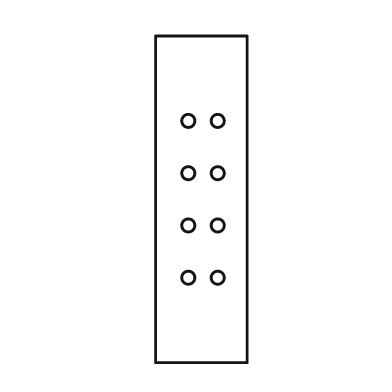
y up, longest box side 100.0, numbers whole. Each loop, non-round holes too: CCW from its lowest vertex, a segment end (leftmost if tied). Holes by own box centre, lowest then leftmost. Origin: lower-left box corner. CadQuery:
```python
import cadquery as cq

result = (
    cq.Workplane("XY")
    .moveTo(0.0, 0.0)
    .lineTo(28.0, 0.0)
    .lineTo(28.0, 100.0)
    .lineTo(0.0, 100.0)
    .close()
    .moveTo(10.0, 26.0)
    .circle(2.0)
    .moveTo(19.0, 26.0)
    .circle(2.0)
    .moveTo(10.0, 42.0)
    .circle(2.0)
    .moveTo(19.0, 42.0)
    .circle(2.0)
    .moveTo(10.0, 58.0)
    .circle(2.0)
    .moveTo(19.0, 58.0)
    .circle(2.0)
    .moveTo(10.0, 74.0)
    .circle(2.0)
    .moveTo(19.0, 74.0)
    .circle(2.0)
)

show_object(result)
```